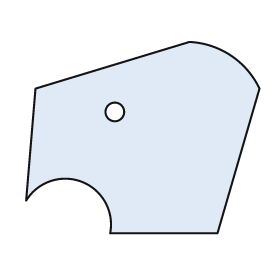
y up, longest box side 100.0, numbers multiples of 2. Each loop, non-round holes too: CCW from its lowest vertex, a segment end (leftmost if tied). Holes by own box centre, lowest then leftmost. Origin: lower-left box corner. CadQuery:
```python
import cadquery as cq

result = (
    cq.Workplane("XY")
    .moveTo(36.0, 0.0)
    .lineTo(82.0, 0.0)
    .lineTo(100.0, 62.0)
    .threePointArc((88.0, 76.0), (70.0, 82.0))
    .lineTo(4.0, 62.0)
    .lineTo(0.0, 14.0)
    .threePointArc((24.0, 22.0), (36.0, 0.0))
    .close()
    .moveTo(38.0, 52.0)
    .circle(4.0)
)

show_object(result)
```